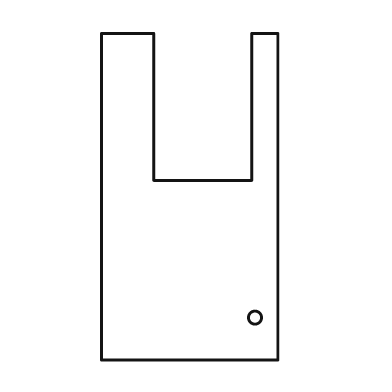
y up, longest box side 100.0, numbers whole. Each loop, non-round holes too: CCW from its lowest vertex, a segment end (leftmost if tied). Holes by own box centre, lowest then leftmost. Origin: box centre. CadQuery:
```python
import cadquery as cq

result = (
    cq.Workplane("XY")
    .moveTo(-27.0, -50.0)
    .lineTo(27.0, -50.0)
    .lineTo(27.0, 50.0)
    .lineTo(19.0, 50.0)
    .lineTo(19.0, 5.0)
    .lineTo(-11.0, 5.0)
    .lineTo(-11.0, 50.0)
    .lineTo(-27.0, 50.0)
    .close()
    .moveTo(20.0, -37.0)
    .circle(2.0)
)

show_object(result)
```